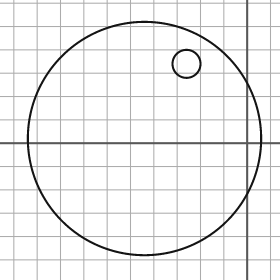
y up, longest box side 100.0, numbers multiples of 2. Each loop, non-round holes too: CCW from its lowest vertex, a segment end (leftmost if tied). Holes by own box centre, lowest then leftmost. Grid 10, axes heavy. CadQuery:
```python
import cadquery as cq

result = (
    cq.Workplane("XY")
    .moveTo(-44.0, 2.0)
    .circle(50.0)
    .moveTo(-26.0, 34.0)
    .circle(6.0)
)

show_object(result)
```